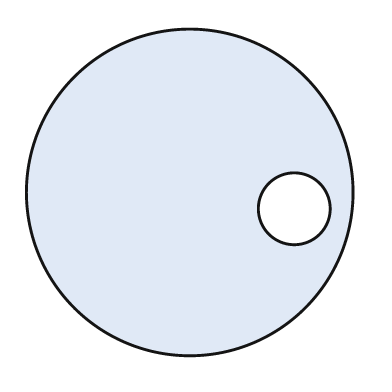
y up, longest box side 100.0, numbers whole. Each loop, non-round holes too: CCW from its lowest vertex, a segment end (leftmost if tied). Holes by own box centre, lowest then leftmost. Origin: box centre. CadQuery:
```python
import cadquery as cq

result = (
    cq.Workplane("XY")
    .moveTo(0.0, 0.0)
    .circle(50.0)
    .moveTo(32.0, -5.0)
    .circle(11.0)
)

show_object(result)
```